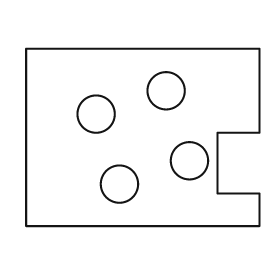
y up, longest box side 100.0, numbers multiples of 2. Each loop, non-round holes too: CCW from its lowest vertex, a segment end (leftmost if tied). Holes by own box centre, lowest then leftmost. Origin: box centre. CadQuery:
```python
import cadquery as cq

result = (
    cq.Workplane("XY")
    .moveTo(-50.0, -38.0)
    .lineTo(50.0, -38.0)
    .lineTo(50.0, -24.0)
    .lineTo(32.0, -24.0)
    .lineTo(32.0, 2.0)
    .lineTo(50.0, 2.0)
    .lineTo(50.0, 38.0)
    .lineTo(-50.0, 38.0)
    .close()
    .moveTo(-10.0, -20.0)
    .circle(8.0)
    .moveTo(20.0, -10.0)
    .circle(8.0)
    .moveTo(-20.0, 10.0)
    .circle(8.0)
    .moveTo(10.0, 20.0)
    .circle(8.0)
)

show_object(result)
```